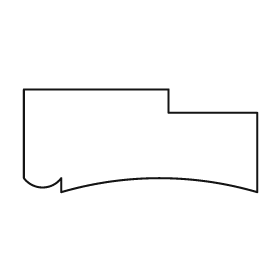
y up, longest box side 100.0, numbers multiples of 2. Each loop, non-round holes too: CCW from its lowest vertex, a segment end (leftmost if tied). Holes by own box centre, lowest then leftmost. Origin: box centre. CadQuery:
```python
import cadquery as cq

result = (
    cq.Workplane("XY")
    .moveTo(-34.0, -22.0)
    .threePointArc((8.0, -16.0), (50.0, -22.0))
    .lineTo(50.0, 12.0)
    .lineTo(12.0, 12.0)
    .lineTo(12.0, 22.0)
    .lineTo(-50.0, 22.0)
    .lineTo(-50.0, -16.0)
    .threePointArc((-42.0, -20.0), (-34.0, -16.0))
    .close()
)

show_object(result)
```